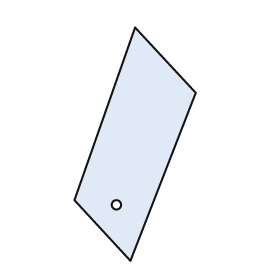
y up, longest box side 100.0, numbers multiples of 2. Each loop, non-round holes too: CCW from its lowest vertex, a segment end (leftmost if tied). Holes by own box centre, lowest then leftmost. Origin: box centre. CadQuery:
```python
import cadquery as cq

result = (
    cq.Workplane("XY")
    .moveTo(-2.0, -50.0)
    .lineTo(26.0, 22.0)
    .lineTo(0.0, 50.0)
    .lineTo(-26.0, -24.0)
    .close()
    .moveTo(-8.0, -26.0)
    .circle(2.0)
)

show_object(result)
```